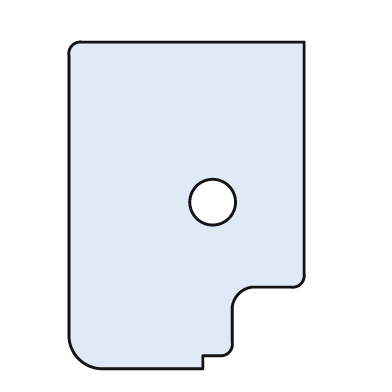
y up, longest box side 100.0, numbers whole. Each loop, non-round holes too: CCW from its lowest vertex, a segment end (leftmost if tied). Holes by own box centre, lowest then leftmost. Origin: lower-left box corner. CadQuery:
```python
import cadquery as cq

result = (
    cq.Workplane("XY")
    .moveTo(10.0, 0.0)
    .lineTo(41.0, 0.0)
    .lineTo(41.0, 4.0)
    .lineTo(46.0, 4.0)
    .threePointArc((49.0, 5.0), (50.0, 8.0))
    .lineTo(50.0, 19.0)
    .threePointArc((52.0, 23.0), (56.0, 25.0))
    .lineTo(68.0, 25.0)
    .threePointArc((71.0, 26.0), (72.0, 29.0))
    .lineTo(72.0, 100.0)
    .lineTo(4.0, 100.0)
    .threePointArc((1.0, 99.0), (0.0, 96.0))
    .lineTo(0.0, 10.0)
    .threePointArc((3.0, 3.0), (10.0, 0.0))
    .close()
    .moveTo(44.0, 51.0)
    .circle(7.0)
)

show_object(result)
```